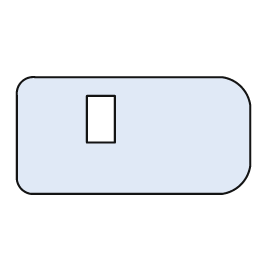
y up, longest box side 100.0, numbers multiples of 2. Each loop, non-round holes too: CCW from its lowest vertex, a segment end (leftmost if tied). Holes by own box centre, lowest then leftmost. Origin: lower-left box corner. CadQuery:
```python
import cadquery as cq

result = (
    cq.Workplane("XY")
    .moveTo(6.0, 0.0)
    .lineTo(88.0, 0.0)
    .threePointArc((96.0, 4.0), (100.0, 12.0))
    .lineTo(100.0, 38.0)
    .threePointArc((96.0, 46.0), (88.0, 50.0))
    .lineTo(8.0, 50.0)
    .threePointArc((2.0, 48.0), (0.0, 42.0))
    .lineTo(0.0, 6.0)
    .threePointArc((2.0, 2.0), (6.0, 0.0))
    .close()
    .moveTo(30.0, 22.0)
    .lineTo(42.0, 22.0)
    .lineTo(42.0, 42.0)
    .lineTo(30.0, 42.0)
    .close()
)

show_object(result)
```